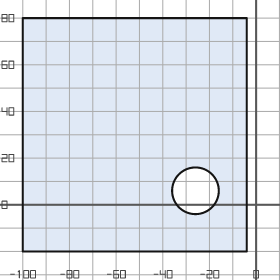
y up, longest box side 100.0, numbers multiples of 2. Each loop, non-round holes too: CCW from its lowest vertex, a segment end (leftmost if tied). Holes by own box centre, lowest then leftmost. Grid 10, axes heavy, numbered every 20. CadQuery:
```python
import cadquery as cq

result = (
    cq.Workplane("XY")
    .moveTo(-100.0, -20.0)
    .lineTo(-4.0, -20.0)
    .lineTo(-4.0, 80.0)
    .lineTo(-100.0, 80.0)
    .close()
    .moveTo(-26.0, 6.0)
    .circle(10.0)
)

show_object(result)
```